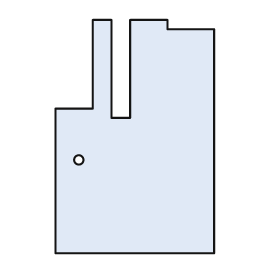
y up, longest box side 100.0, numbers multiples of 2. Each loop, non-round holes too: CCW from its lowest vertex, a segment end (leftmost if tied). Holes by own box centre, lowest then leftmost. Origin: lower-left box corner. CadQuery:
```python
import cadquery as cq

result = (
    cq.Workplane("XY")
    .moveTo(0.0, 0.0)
    .lineTo(68.0, 0.0)
    .lineTo(68.0, 96.0)
    .lineTo(48.0, 96.0)
    .lineTo(48.0, 100.0)
    .lineTo(32.0, 100.0)
    .lineTo(32.0, 58.0)
    .lineTo(24.0, 58.0)
    .lineTo(24.0, 100.0)
    .lineTo(16.0, 100.0)
    .lineTo(16.0, 62.0)
    .lineTo(0.0, 62.0)
    .close()
    .moveTo(10.0, 40.0)
    .circle(2.0)
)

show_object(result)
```